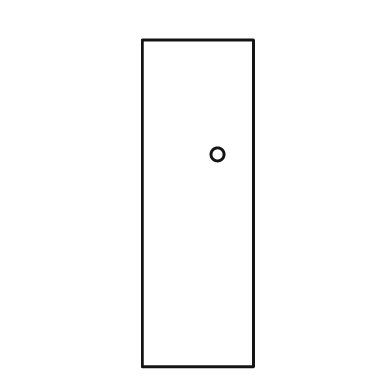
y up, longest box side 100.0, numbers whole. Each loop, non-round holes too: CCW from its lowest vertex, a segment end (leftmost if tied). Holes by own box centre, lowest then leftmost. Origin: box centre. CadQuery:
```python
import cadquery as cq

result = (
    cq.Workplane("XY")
    .moveTo(-17.0, -50.0)
    .lineTo(17.0, -50.0)
    .lineTo(17.0, 50.0)
    .lineTo(-17.0, 50.0)
    .close()
    .moveTo(6.0, 15.0)
    .circle(2.0)
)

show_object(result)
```